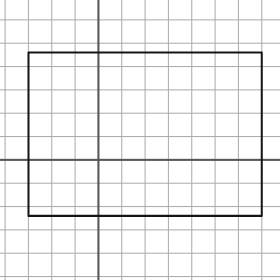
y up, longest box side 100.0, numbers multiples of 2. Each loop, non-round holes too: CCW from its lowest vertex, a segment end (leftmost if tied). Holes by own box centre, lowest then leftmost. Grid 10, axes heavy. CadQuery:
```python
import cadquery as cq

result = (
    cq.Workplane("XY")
    .moveTo(-30.0, -24.0)
    .lineTo(70.0, -24.0)
    .lineTo(70.0, 46.0)
    .lineTo(-30.0, 46.0)
    .close()
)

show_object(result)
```